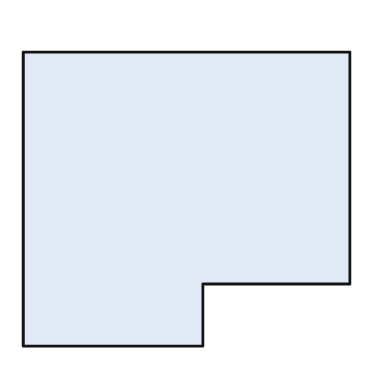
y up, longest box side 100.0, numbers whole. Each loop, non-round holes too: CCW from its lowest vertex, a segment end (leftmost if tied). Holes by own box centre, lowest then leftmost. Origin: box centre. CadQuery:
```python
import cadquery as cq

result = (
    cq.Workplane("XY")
    .moveTo(-50.0, -45.0)
    .lineTo(5.0, -45.0)
    .lineTo(5.0, -26.0)
    .lineTo(50.0, -26.0)
    .lineTo(50.0, 45.0)
    .lineTo(-50.0, 45.0)
    .close()
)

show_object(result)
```